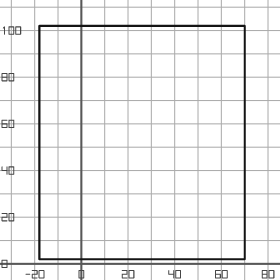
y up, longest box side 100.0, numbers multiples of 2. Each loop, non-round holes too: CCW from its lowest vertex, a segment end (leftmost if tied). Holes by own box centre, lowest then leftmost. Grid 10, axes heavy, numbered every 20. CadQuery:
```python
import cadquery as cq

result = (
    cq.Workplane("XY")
    .moveTo(-18.0, 2.0)
    .lineTo(70.0, 2.0)
    .lineTo(70.0, 102.0)
    .lineTo(-18.0, 102.0)
    .close()
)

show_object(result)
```